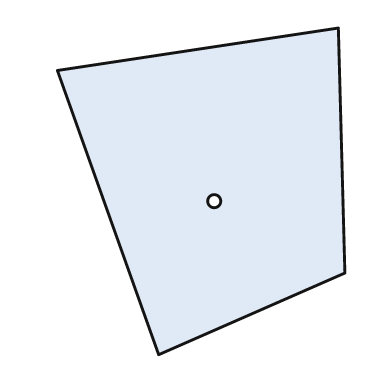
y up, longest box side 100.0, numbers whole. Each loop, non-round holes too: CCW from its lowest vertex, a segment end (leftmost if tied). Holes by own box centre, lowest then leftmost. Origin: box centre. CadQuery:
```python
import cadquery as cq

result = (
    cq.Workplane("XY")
    .moveTo(-13.0, -50.0)
    .lineTo(44.0, -25.0)
    .lineTo(42.0, 50.0)
    .lineTo(-44.0, 37.0)
    .close()
    .moveTo(4.0, -3.0)
    .circle(2.0)
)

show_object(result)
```